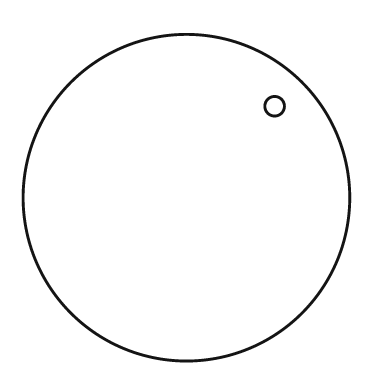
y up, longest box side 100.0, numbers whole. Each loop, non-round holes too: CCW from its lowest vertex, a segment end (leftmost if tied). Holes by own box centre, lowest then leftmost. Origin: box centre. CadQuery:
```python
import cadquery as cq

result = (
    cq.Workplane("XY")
    .moveTo(0.0, 0.0)
    .circle(50.0)
    .moveTo(27.0, 28.0)
    .circle(3.0)
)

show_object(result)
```